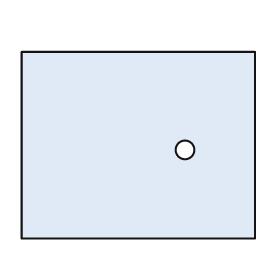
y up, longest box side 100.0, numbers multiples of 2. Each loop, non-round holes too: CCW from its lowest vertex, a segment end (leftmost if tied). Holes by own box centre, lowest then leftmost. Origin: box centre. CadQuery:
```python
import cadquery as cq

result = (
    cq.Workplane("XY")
    .moveTo(-50.0, -40.0)
    .lineTo(50.0, -40.0)
    .lineTo(50.0, 40.0)
    .lineTo(-50.0, 40.0)
    .close()
    .moveTo(20.0, -2.0)
    .circle(4.0)
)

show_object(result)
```